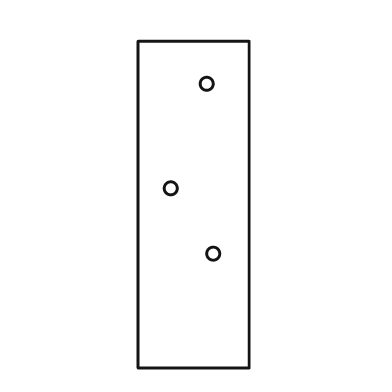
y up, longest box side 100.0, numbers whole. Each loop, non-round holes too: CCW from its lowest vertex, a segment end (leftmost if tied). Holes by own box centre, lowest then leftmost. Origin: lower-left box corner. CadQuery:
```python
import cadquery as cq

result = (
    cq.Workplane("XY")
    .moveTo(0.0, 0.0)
    .lineTo(34.0, 0.0)
    .lineTo(34.0, 100.0)
    .lineTo(0.0, 100.0)
    .close()
    .moveTo(23.0, 35.0)
    .circle(2.0)
    .moveTo(10.0, 55.0)
    .circle(2.0)
    .moveTo(21.0, 87.0)
    .circle(2.0)
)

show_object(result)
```